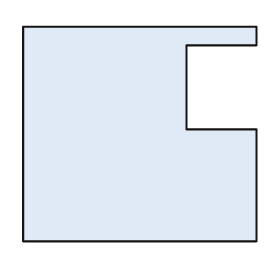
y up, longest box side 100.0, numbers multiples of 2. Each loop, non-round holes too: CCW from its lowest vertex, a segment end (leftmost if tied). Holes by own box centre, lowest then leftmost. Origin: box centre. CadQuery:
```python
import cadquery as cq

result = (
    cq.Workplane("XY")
    .moveTo(-50.0, -46.0)
    .lineTo(50.0, -46.0)
    .lineTo(50.0, 2.0)
    .lineTo(20.0, 2.0)
    .lineTo(20.0, 38.0)
    .lineTo(50.0, 38.0)
    .lineTo(50.0, 46.0)
    .lineTo(-50.0, 46.0)
    .close()
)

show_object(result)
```